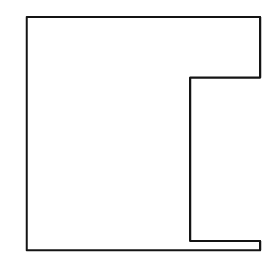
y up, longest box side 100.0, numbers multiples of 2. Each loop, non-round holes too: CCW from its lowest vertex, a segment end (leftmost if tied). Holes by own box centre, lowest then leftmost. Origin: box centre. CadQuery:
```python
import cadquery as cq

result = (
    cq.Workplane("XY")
    .moveTo(-50.0, -50.0)
    .lineTo(50.0, -50.0)
    .lineTo(50.0, -46.0)
    .lineTo(20.0, -46.0)
    .lineTo(20.0, 24.0)
    .lineTo(50.0, 24.0)
    .lineTo(50.0, 50.0)
    .lineTo(-50.0, 50.0)
    .close()
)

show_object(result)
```